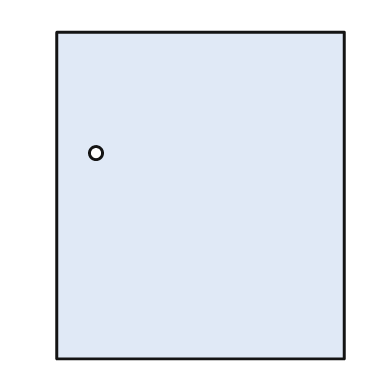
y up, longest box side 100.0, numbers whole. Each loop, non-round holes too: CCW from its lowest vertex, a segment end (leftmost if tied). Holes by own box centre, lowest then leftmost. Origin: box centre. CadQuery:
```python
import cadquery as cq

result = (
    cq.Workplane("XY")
    .moveTo(-44.0, -50.0)
    .lineTo(44.0, -50.0)
    .lineTo(44.0, 50.0)
    .lineTo(-44.0, 50.0)
    .close()
    .moveTo(-32.0, 13.0)
    .circle(2.0)
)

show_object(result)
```